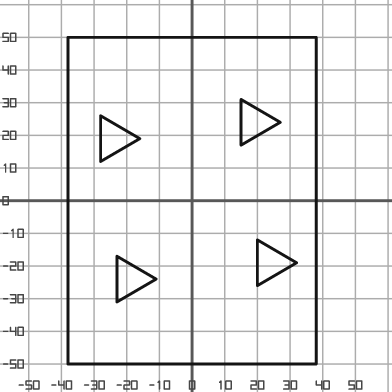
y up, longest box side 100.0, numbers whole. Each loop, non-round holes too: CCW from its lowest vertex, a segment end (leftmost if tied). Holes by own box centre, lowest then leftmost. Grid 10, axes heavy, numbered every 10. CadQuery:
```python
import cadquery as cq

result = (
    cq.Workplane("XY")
    .moveTo(-38.0, -50.0)
    .lineTo(38.0, -50.0)
    .lineTo(38.0, 50.0)
    .lineTo(-38.0, 50.0)
    .close()
    .moveTo(-23.0, -31.0)
    .lineTo(-11.0, -24.0)
    .lineTo(-23.0, -17.0)
    .close()
    .moveTo(20.0, -26.0)
    .lineTo(32.0, -19.0)
    .lineTo(20.0, -12.0)
    .close()
    .moveTo(-28.0, 12.0)
    .lineTo(-16.0, 19.0)
    .lineTo(-28.0, 26.0)
    .close()
    .moveTo(15.0, 17.0)
    .lineTo(27.0, 24.0)
    .lineTo(15.0, 31.0)
    .close()
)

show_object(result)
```